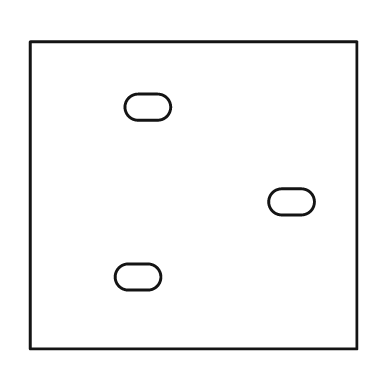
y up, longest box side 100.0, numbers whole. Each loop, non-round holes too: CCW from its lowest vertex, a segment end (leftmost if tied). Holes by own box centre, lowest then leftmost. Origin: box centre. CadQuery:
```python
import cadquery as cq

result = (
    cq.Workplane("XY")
    .moveTo(-50.0, -47.0)
    .lineTo(50.0, -47.0)
    .lineTo(50.0, 47.0)
    .lineTo(-50.0, 47.0)
    .close()
    .moveTo(-20.0, -29.0)
    .lineTo(-14.0, -29.0)
    .threePointArc((-10.0, -25.0), (-14.0, -21.0))
    .lineTo(-20.0, -21.0)
    .threePointArc((-24.0, -25.0), (-20.0, -29.0))
    .close()
    .moveTo(27.0, -6.0)
    .lineTo(33.0, -6.0)
    .threePointArc((37.0, -2.0), (33.0, 2.0))
    .lineTo(27.0, 2.0)
    .threePointArc((23.0, -2.0), (27.0, -6.0))
    .close()
    .moveTo(-17.0, 23.0)
    .lineTo(-11.0, 23.0)
    .threePointArc((-7.0, 27.0), (-11.0, 31.0))
    .lineTo(-17.0, 31.0)
    .threePointArc((-21.0, 27.0), (-17.0, 23.0))
    .close()
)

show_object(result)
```